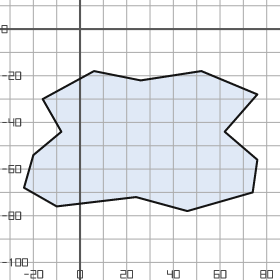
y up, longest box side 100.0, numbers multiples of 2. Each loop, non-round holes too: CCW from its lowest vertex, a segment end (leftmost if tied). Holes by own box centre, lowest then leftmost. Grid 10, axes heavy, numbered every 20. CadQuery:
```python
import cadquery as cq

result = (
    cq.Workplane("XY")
    .moveTo(46.0, -78.0)
    .lineTo(74.0, -70.0)
    .lineTo(76.0, -56.0)
    .lineTo(62.0, -44.0)
    .lineTo(76.0, -28.0)
    .lineTo(52.0, -18.0)
    .lineTo(26.0, -22.0)
    .lineTo(6.0, -18.0)
    .lineTo(-16.0, -30.0)
    .lineTo(-8.0, -44.0)
    .lineTo(-20.0, -54.0)
    .lineTo(-24.0, -68.0)
    .lineTo(-10.0, -76.0)
    .lineTo(24.0, -72.0)
    .close()
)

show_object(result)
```